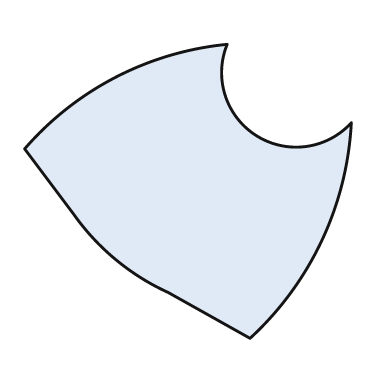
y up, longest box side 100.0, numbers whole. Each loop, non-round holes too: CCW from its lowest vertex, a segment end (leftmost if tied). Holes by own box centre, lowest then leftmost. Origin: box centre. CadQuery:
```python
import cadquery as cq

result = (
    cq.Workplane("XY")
    .moveTo(19.0, -45.0)
    .threePointArc((41.0, -15.0), (50.0, 21.0))
    .threePointArc((21.0, 17.0), (12.0, 45.0))
    .threePointArc((-22.0, 35.0), (-50.0, 13.0))
    .lineTo(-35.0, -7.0)
    .threePointArc((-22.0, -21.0), (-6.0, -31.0))
    .close()
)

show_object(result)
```